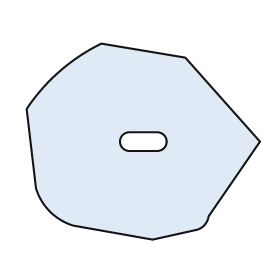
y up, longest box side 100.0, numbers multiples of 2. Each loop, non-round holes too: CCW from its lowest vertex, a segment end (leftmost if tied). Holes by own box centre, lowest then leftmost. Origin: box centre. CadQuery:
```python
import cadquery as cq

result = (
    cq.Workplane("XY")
    .moveTo(4.0, -42.0)
    .lineTo(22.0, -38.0)
    .threePointArc((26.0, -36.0), (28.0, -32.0))
    .lineTo(50.0, 0.0)
    .lineTo(18.0, 36.0)
    .lineTo(-18.0, 42.0)
    .threePointArc((-36.0, 30.0), (-50.0, 14.0))
    .lineTo(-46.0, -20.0)
    .threePointArc((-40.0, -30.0), (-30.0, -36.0))
    .close()
    .moveTo(-6.0, -4.0)
    .lineTo(6.0, -4.0)
    .threePointArc((10.0, 0.0), (6.0, 4.0))
    .lineTo(-6.0, 4.0)
    .threePointArc((-10.0, 0.0), (-6.0, -4.0))
    .close()
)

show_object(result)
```